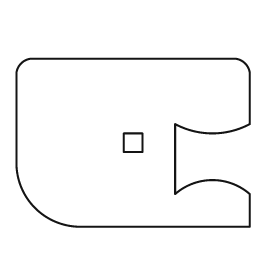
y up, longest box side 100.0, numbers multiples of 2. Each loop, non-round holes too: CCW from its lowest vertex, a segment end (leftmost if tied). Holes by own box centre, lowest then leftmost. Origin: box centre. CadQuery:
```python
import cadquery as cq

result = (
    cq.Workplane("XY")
    .moveTo(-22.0, -36.0)
    .lineTo(50.0, -36.0)
    .lineTo(50.0, -22.0)
    .threePointArc((34.0, -16.0), (18.0, -22.0))
    .lineTo(18.0, 8.0)
    .threePointArc((34.0, 4.0), (50.0, 8.0))
    .lineTo(50.0, 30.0)
    .threePointArc((48.0, 34.0), (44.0, 36.0))
    .lineTo(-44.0, 36.0)
    .threePointArc((-48.0, 34.0), (-50.0, 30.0))
    .lineTo(-50.0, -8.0)
    .threePointArc((-42.0, -28.0), (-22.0, -36.0))
    .close()
    .moveTo(-4.0, -4.0)
    .lineTo(4.0, -4.0)
    .lineTo(4.0, 4.0)
    .lineTo(-4.0, 4.0)
    .close()
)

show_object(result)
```